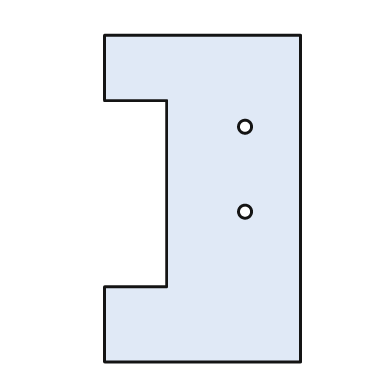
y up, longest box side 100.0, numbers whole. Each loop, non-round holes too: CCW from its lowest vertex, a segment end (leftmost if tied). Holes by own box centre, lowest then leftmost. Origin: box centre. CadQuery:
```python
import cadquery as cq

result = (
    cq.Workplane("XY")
    .moveTo(-30.0, -50.0)
    .lineTo(30.0, -50.0)
    .lineTo(30.0, 50.0)
    .lineTo(-30.0, 50.0)
    .lineTo(-30.0, 30.0)
    .lineTo(-11.0, 30.0)
    .lineTo(-11.0, -27.0)
    .lineTo(-30.0, -27.0)
    .close()
    .moveTo(13.0, -4.0)
    .circle(2.0)
    .moveTo(13.0, 22.0)
    .circle(2.0)
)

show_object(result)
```